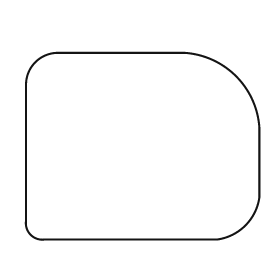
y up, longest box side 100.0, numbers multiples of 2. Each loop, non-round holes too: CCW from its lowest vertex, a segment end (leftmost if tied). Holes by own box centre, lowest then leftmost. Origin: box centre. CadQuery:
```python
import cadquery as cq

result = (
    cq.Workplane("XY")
    .moveTo(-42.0, -40.0)
    .lineTo(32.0, -40.0)
    .threePointArc((44.0, -34.0), (50.0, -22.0))
    .lineTo(50.0, 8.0)
    .threePointArc((40.0, 30.0), (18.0, 40.0))
    .lineTo(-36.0, 40.0)
    .threePointArc((-46.0, 36.0), (-50.0, 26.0))
    .lineTo(-50.0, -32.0)
    .threePointArc((-48.0, -38.0), (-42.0, -40.0))
    .close()
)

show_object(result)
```